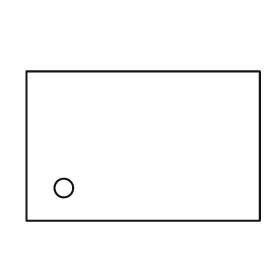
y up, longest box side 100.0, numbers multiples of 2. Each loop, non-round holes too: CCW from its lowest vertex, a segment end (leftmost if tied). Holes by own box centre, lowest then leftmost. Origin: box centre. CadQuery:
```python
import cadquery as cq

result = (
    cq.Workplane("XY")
    .moveTo(-50.0, -32.0)
    .lineTo(50.0, -32.0)
    .lineTo(50.0, 32.0)
    .lineTo(-50.0, 32.0)
    .close()
    .moveTo(-34.0, -18.0)
    .circle(4.0)
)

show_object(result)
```